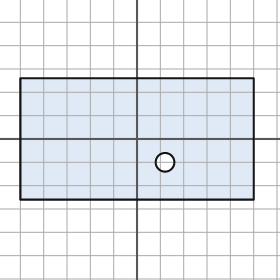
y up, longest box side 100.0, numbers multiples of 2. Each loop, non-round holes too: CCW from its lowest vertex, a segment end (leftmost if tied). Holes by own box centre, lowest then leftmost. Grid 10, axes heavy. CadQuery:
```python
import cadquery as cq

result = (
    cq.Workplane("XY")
    .moveTo(-50.0, -26.0)
    .lineTo(50.0, -26.0)
    .lineTo(50.0, 26.0)
    .lineTo(-50.0, 26.0)
    .close()
    .moveTo(12.0, -10.0)
    .circle(4.0)
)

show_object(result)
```